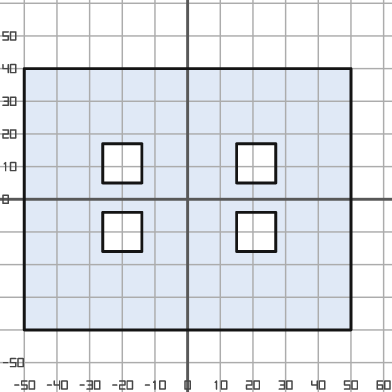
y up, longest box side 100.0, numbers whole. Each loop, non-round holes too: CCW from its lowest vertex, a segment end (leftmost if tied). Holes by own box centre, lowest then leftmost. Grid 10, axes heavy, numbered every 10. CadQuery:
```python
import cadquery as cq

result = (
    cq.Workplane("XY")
    .moveTo(-50.0, -40.0)
    .lineTo(50.0, -40.0)
    .lineTo(50.0, 40.0)
    .lineTo(-50.0, 40.0)
    .close()
    .moveTo(-26.0, -16.0)
    .lineTo(-14.0, -16.0)
    .lineTo(-14.0, -4.0)
    .lineTo(-26.0, -4.0)
    .close()
    .moveTo(15.0, -16.0)
    .lineTo(27.0, -16.0)
    .lineTo(27.0, -4.0)
    .lineTo(15.0, -4.0)
    .close()
    .moveTo(-26.0, 5.0)
    .lineTo(-14.0, 5.0)
    .lineTo(-14.0, 17.0)
    .lineTo(-26.0, 17.0)
    .close()
    .moveTo(15.0, 5.0)
    .lineTo(27.0, 5.0)
    .lineTo(27.0, 17.0)
    .lineTo(15.0, 17.0)
    .close()
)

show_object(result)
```